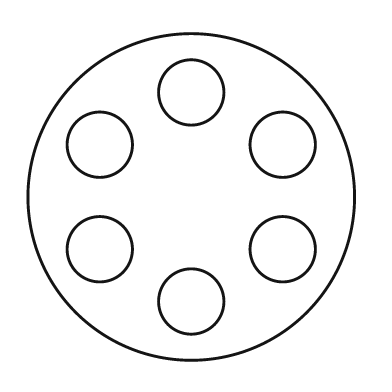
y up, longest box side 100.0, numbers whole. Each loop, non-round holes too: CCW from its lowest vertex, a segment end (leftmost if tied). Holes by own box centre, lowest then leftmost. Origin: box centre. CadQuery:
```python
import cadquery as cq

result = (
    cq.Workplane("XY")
    .moveTo(0.0, 0.0)
    .circle(50.0)
    .moveTo(0.0, -32.0)
    .circle(10.0)
    .moveTo(-28.0, -16.0)
    .circle(10.0)
    .moveTo(28.0, -16.0)
    .circle(10.0)
    .moveTo(-28.0, 16.0)
    .circle(10.0)
    .moveTo(28.0, 16.0)
    .circle(10.0)
    .moveTo(0.0, 32.0)
    .circle(10.0)
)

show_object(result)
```